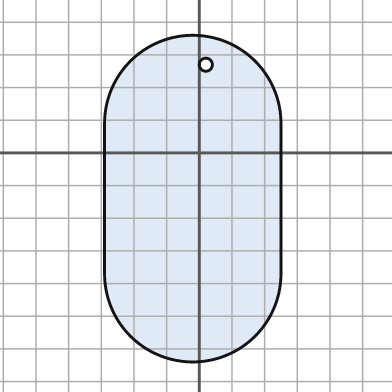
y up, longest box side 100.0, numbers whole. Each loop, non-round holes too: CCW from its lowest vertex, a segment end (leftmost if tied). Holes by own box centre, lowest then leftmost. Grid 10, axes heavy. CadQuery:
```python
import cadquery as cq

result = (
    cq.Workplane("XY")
    .moveTo(-29.0, -37.0)
    .threePointArc((-2.0, -64.0), (25.0, -37.0))
    .lineTo(25.0, 9.0)
    .threePointArc((-2.0, 36.0), (-29.0, 9.0))
    .close()
    .moveTo(2.0, 27.0)
    .circle(2.0)
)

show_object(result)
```